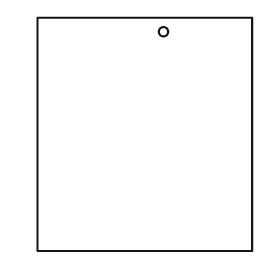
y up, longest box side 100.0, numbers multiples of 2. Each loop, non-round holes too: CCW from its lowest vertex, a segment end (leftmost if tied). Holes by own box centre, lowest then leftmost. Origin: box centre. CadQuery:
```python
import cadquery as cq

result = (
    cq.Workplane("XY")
    .moveTo(-46.0, -50.0)
    .lineTo(46.0, -50.0)
    .lineTo(46.0, 50.0)
    .lineTo(-46.0, 50.0)
    .close()
    .moveTo(8.0, 44.0)
    .circle(2.0)
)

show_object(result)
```